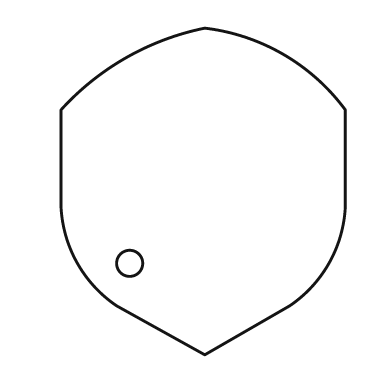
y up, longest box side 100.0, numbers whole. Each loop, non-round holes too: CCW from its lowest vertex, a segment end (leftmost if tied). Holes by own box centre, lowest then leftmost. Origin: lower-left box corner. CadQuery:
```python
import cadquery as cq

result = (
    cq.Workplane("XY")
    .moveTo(44.0, 0.0)
    .lineTo(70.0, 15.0)
    .threePointArc((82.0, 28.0), (87.0, 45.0))
    .lineTo(87.0, 75.0)
    .threePointArc((68.0, 92.0), (44.0, 100.0))
    .threePointArc((20.0, 91.0), (0.0, 75.0))
    .lineTo(0.0, 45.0)
    .threePointArc((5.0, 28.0), (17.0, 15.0))
    .close()
    .moveTo(21.0, 28.0)
    .circle(4.0)
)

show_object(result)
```